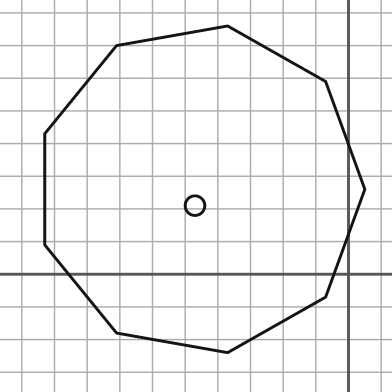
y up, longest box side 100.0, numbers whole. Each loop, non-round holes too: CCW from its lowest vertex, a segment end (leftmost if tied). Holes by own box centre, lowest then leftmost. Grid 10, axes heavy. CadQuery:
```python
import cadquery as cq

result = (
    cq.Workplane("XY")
    .moveTo(-37.0, -24.0)
    .lineTo(-7.0, -7.0)
    .lineTo(5.0, 26.0)
    .lineTo(-7.0, 59.0)
    .lineTo(-37.0, 76.0)
    .lineTo(-71.0, 70.0)
    .lineTo(-93.0, 43.0)
    .lineTo(-93.0, 9.0)
    .lineTo(-71.0, -18.0)
    .close()
    .moveTo(-47.0, 21.0)
    .circle(3.0)
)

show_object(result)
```